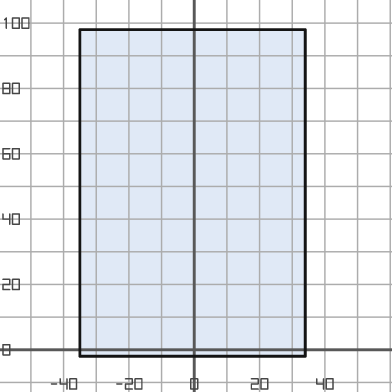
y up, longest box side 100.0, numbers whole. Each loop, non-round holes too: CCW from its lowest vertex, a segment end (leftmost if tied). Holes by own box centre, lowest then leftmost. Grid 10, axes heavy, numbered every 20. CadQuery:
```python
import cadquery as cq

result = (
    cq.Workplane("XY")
    .moveTo(-35.0, -2.0)
    .lineTo(34.0, -2.0)
    .lineTo(34.0, 98.0)
    .lineTo(-35.0, 98.0)
    .close()
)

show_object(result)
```